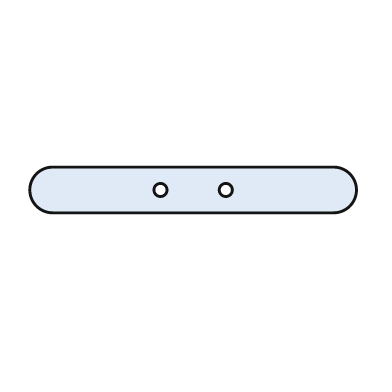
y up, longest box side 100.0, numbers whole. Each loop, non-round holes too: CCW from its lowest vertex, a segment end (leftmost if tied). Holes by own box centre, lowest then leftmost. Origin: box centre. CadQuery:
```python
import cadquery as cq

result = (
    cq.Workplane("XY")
    .moveTo(-43.0, -7.0)
    .lineTo(43.0, -7.0)
    .threePointArc((50.0, 0.0), (43.0, 7.0))
    .lineTo(-43.0, 7.0)
    .threePointArc((-50.0, 0.0), (-43.0, -7.0))
    .close()
    .moveTo(-10.0, 0.0)
    .circle(2.0)
    .moveTo(10.0, 0.0)
    .circle(2.0)
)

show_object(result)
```